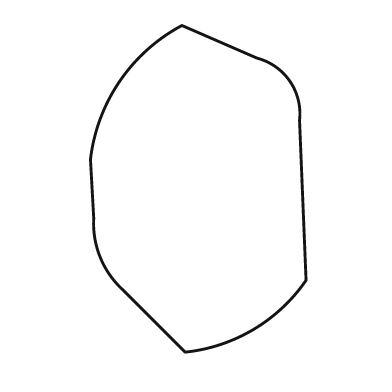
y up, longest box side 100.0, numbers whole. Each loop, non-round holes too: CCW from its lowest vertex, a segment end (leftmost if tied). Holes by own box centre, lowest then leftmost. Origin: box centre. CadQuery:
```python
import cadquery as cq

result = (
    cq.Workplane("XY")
    .moveTo(-4.0, -50.0)
    .threePointArc((17.0, -43.0), (33.0, -28.0))
    .lineTo(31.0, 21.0)
    .threePointArc((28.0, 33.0), (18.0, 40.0))
    .lineTo(-5.0, 50.0)
    .threePointArc((-24.0, 33.0), (-33.0, 9.0))
    .lineTo(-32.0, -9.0)
    .threePointArc((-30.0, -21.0), (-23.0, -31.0))
    .close()
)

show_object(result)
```